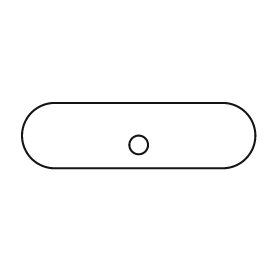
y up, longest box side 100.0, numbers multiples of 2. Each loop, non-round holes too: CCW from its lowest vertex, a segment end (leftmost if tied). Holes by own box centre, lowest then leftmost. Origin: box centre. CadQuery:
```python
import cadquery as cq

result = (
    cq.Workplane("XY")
    .moveTo(-36.0, -14.0)
    .lineTo(36.0, -14.0)
    .threePointArc((50.0, 0.0), (36.0, 14.0))
    .lineTo(-36.0, 14.0)
    .threePointArc((-50.0, 0.0), (-36.0, -14.0))
    .close()
    .moveTo(0.0, -4.0)
    .circle(4.0)
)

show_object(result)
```